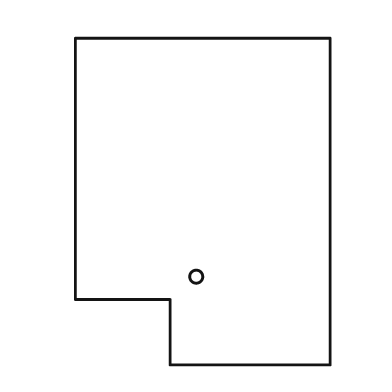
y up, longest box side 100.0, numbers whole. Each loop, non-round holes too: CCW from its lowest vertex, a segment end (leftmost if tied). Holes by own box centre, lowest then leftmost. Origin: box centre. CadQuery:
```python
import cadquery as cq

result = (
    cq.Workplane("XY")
    .moveTo(-10.0, -50.0)
    .lineTo(39.0, -50.0)
    .lineTo(39.0, 50.0)
    .lineTo(-39.0, 50.0)
    .lineTo(-39.0, -30.0)
    .lineTo(-10.0, -30.0)
    .close()
    .moveTo(-2.0, -23.0)
    .circle(2.0)
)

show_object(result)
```